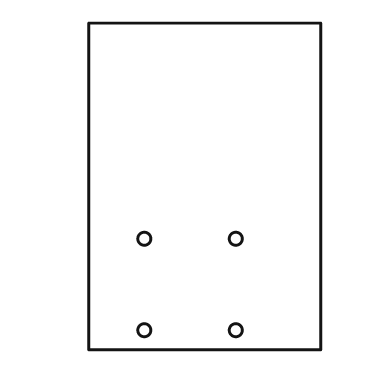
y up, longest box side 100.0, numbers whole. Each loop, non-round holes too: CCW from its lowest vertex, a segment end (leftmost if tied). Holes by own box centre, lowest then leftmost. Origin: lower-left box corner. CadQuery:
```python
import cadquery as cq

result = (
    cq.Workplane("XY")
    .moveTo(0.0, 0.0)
    .lineTo(71.0, 0.0)
    .lineTo(71.0, 100.0)
    .lineTo(0.0, 100.0)
    .close()
    .moveTo(17.0, 6.0)
    .circle(2.0)
    .moveTo(45.0, 6.0)
    .circle(2.0)
    .moveTo(17.0, 34.0)
    .circle(2.0)
    .moveTo(45.0, 34.0)
    .circle(2.0)
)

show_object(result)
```